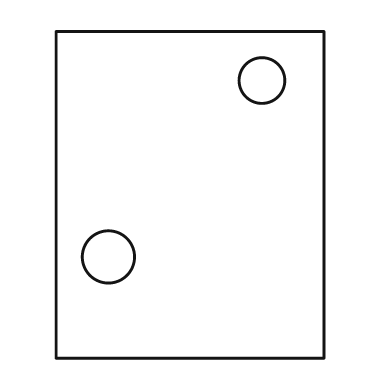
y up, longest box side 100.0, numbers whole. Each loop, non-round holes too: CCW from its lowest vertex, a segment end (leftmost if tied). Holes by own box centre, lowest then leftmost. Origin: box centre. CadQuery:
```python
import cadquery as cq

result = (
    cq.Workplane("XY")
    .moveTo(-41.0, -50.0)
    .lineTo(41.0, -50.0)
    .lineTo(41.0, 50.0)
    .lineTo(-41.0, 50.0)
    .close()
    .moveTo(-25.0, -19.0)
    .circle(8.0)
    .moveTo(22.0, 35.0)
    .circle(7.0)
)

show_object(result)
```